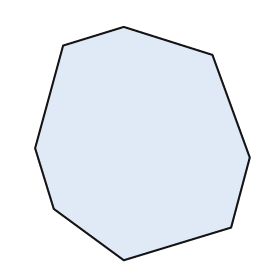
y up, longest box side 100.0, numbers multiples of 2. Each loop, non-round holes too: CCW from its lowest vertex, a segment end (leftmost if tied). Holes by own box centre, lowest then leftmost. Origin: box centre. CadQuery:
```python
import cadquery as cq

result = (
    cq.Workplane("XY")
    .moveTo(-8.0, -50.0)
    .lineTo(38.0, -36.0)
    .lineTo(46.0, -6.0)
    .lineTo(30.0, 38.0)
    .lineTo(-8.0, 50.0)
    .lineTo(-34.0, 42.0)
    .lineTo(-46.0, -2.0)
    .lineTo(-38.0, -28.0)
    .close()
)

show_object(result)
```